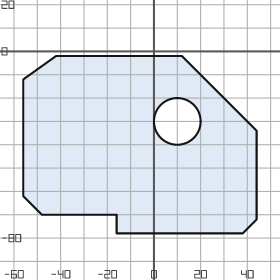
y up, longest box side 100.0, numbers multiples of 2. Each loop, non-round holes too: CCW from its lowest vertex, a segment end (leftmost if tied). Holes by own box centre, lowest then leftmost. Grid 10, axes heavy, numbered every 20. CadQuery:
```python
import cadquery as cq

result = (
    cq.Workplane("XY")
    .moveTo(-16.0, -78.0)
    .lineTo(38.0, -78.0)
    .lineTo(44.0, -72.0)
    .lineTo(44.0, -34.0)
    .lineTo(12.0, -2.0)
    .lineTo(-42.0, -2.0)
    .lineTo(-56.0, -12.0)
    .lineTo(-56.0, -62.0)
    .lineTo(-48.0, -70.0)
    .lineTo(-16.0, -70.0)
    .close()
    .moveTo(10.0, -30.0)
    .circle(10.0)
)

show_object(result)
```